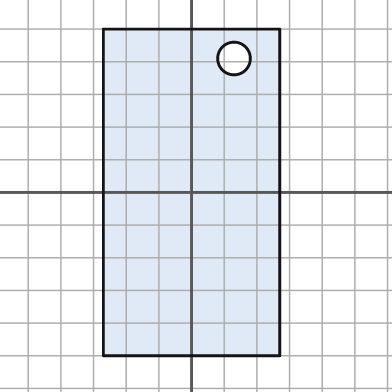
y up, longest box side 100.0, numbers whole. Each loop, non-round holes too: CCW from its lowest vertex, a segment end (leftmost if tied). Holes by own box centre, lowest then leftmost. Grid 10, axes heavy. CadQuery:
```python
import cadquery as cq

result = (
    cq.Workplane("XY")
    .moveTo(-27.0, -50.0)
    .lineTo(27.0, -50.0)
    .lineTo(27.0, 50.0)
    .lineTo(-27.0, 50.0)
    .close()
    .moveTo(13.0, 41.0)
    .circle(5.0)
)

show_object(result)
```